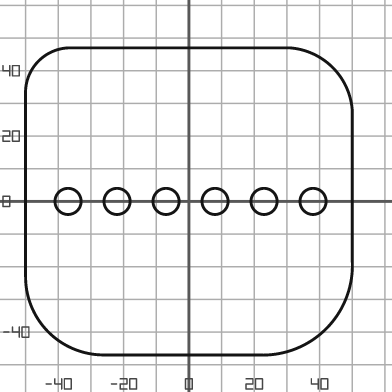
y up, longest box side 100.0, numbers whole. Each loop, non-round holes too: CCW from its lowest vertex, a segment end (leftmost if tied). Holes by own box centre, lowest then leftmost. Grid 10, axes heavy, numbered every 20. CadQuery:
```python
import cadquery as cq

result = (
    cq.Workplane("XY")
    .moveTo(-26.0, -47.0)
    .lineTo(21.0, -47.0)
    .threePointArc((42.0, -39.0), (50.0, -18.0))
    .lineTo(50.0, 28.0)
    .threePointArc((44.0, 41.0), (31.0, 47.0))
    .lineTo(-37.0, 47.0)
    .threePointArc((-46.0, 43.0), (-50.0, 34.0))
    .lineTo(-50.0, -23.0)
    .threePointArc((-43.0, -40.0), (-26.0, -47.0))
    .close()
    .moveTo(-37.0, 0.0)
    .circle(4.0)
    .moveTo(-22.0, 0.0)
    .circle(4.0)
    .moveTo(-7.0, 0.0)
    .circle(4.0)
    .moveTo(8.0, 0.0)
    .circle(4.0)
    .moveTo(23.0, 0.0)
    .circle(4.0)
    .moveTo(38.0, 0.0)
    .circle(4.0)
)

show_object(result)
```